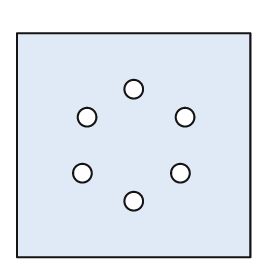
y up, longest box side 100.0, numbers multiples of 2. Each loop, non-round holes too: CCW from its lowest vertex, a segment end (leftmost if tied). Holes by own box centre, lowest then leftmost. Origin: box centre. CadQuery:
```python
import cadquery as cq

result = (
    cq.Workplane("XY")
    .moveTo(-50.0, -48.0)
    .lineTo(50.0, -48.0)
    .lineTo(50.0, 48.0)
    .lineTo(-50.0, 48.0)
    .close()
    .moveTo(0.0, -24.0)
    .circle(4.0)
    .moveTo(-22.0, -12.0)
    .circle(4.0)
    .moveTo(20.0, -12.0)
    .circle(4.0)
    .moveTo(-20.0, 12.0)
    .circle(4.0)
    .moveTo(22.0, 12.0)
    .circle(4.0)
    .moveTo(0.0, 24.0)
    .circle(4.0)
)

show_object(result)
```